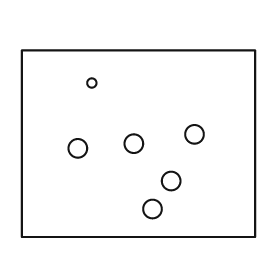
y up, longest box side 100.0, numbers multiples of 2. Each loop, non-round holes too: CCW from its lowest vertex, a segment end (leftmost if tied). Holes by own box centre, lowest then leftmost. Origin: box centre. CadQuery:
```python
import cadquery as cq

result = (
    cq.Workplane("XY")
    .moveTo(-50.0, -40.0)
    .lineTo(50.0, -40.0)
    .lineTo(50.0, 40.0)
    .lineTo(-50.0, 40.0)
    .close()
    .moveTo(6.0, -28.0)
    .circle(4.0)
    .moveTo(14.0, -16.0)
    .circle(4.0)
    .moveTo(-26.0, -2.0)
    .circle(4.0)
    .moveTo(-2.0, 0.0)
    .circle(4.0)
    .moveTo(24.0, 4.0)
    .circle(4.0)
    .moveTo(-20.0, 26.0)
    .circle(2.0)
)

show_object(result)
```